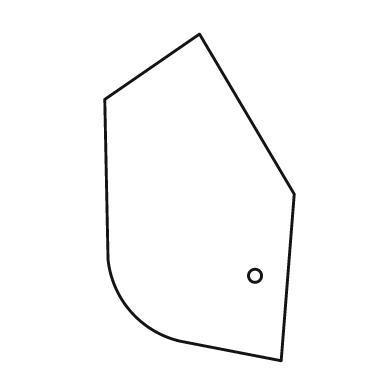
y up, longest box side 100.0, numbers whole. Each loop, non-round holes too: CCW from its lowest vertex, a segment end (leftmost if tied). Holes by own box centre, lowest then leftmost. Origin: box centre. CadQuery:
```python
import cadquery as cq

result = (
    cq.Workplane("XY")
    .moveTo(25.0, -50.0)
    .lineTo(29.0, 1.0)
    .lineTo(0.0, 50.0)
    .lineTo(-29.0, 30.0)
    .lineTo(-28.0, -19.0)
    .threePointArc((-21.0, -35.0), (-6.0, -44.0))
    .close()
    .moveTo(17.0, -24.0)
    .circle(2.0)
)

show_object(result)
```